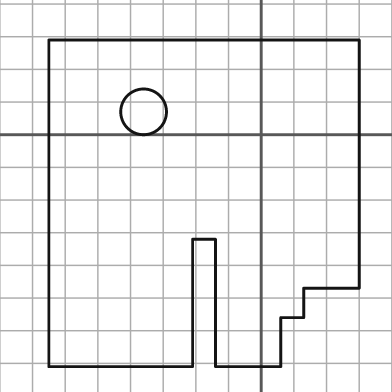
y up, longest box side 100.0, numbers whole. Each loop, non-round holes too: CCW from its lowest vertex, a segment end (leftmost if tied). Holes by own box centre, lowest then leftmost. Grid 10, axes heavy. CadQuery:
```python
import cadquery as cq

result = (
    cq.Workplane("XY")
    .moveTo(-65.0, -71.0)
    .lineTo(-21.0, -71.0)
    .lineTo(-21.0, -32.0)
    .lineTo(-14.0, -32.0)
    .lineTo(-14.0, -71.0)
    .lineTo(6.0, -71.0)
    .lineTo(6.0, -56.0)
    .lineTo(13.0, -56.0)
    .lineTo(13.0, -47.0)
    .lineTo(30.0, -47.0)
    .lineTo(30.0, 29.0)
    .lineTo(-65.0, 29.0)
    .close()
    .moveTo(-36.0, 7.0)
    .circle(7.0)
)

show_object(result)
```